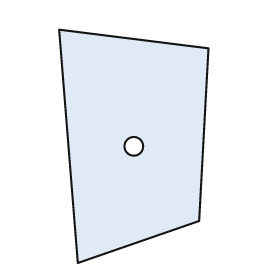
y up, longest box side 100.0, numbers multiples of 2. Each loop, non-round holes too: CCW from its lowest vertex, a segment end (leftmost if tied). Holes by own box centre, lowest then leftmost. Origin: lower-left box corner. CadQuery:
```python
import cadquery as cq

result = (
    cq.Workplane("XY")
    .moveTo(8.0, 0.0)
    .lineTo(60.0, 18.0)
    .lineTo(64.0, 92.0)
    .lineTo(0.0, 100.0)
    .close()
    .moveTo(32.0, 50.0)
    .circle(4.0)
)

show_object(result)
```